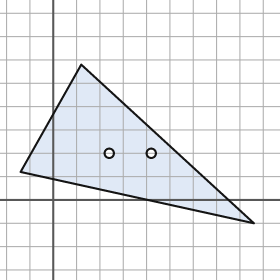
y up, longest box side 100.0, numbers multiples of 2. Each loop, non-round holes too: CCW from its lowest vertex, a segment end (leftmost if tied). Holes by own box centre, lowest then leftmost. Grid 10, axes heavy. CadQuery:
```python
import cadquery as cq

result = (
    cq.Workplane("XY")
    .moveTo(86.0, -10.0)
    .lineTo(12.0, 58.0)
    .lineTo(-14.0, 12.0)
    .close()
    .moveTo(24.0, 20.0)
    .circle(2.0)
    .moveTo(42.0, 20.0)
    .circle(2.0)
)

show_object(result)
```